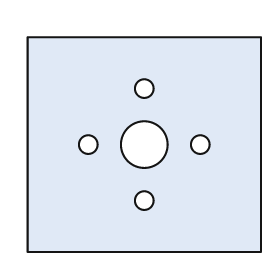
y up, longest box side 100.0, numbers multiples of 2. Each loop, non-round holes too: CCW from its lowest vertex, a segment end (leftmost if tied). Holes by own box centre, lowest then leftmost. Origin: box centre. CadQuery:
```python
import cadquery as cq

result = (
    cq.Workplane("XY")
    .moveTo(-50.0, -46.0)
    .lineTo(50.0, -46.0)
    .lineTo(50.0, 46.0)
    .lineTo(-50.0, 46.0)
    .close()
    .moveTo(0.0, -24.0)
    .circle(4.0)
    .moveTo(-24.0, 0.0)
    .circle(4.0)
    .moveTo(0.0, 0.0)
    .circle(10.0)
    .moveTo(24.0, 0.0)
    .circle(4.0)
    .moveTo(0.0, 24.0)
    .circle(4.0)
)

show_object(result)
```